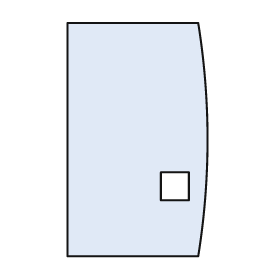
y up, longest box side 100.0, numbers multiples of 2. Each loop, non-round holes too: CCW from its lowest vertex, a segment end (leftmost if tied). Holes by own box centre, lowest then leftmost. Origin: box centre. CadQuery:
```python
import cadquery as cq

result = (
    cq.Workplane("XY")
    .moveTo(-30.0, -50.0)
    .lineTo(26.0, -50.0)
    .threePointArc((30.0, 0.0), (26.0, 50.0))
    .lineTo(-30.0, 50.0)
    .close()
    .moveTo(10.0, -26.0)
    .lineTo(22.0, -26.0)
    .lineTo(22.0, -14.0)
    .lineTo(10.0, -14.0)
    .close()
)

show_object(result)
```